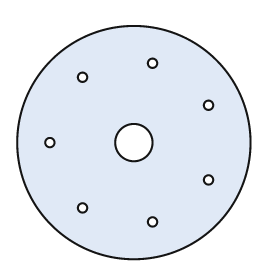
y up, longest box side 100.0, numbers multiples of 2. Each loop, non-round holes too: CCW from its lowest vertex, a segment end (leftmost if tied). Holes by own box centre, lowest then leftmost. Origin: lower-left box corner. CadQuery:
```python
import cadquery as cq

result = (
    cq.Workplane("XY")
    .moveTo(50.0, 50.0)
    .circle(50.0)
    .moveTo(58.0, 16.0)
    .circle(2.0)
    .moveTo(28.0, 22.0)
    .circle(2.0)
    .moveTo(82.0, 34.0)
    .circle(2.0)
    .moveTo(14.0, 50.0)
    .circle(2.0)
    .moveTo(50.0, 50.0)
    .circle(8.0)
    .moveTo(82.0, 66.0)
    .circle(2.0)
    .moveTo(28.0, 78.0)
    .circle(2.0)
    .moveTo(58.0, 84.0)
    .circle(2.0)
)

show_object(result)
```